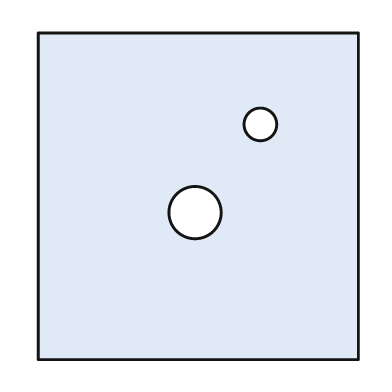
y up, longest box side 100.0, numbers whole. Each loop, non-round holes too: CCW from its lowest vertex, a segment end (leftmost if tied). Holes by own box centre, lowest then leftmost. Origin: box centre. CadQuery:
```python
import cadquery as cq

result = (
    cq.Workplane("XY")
    .moveTo(-49.0, -50.0)
    .lineTo(49.0, -50.0)
    .lineTo(49.0, 50.0)
    .lineTo(-49.0, 50.0)
    .close()
    .moveTo(-1.0, -5.0)
    .circle(8.0)
    .moveTo(19.0, 22.0)
    .circle(5.0)
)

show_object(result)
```